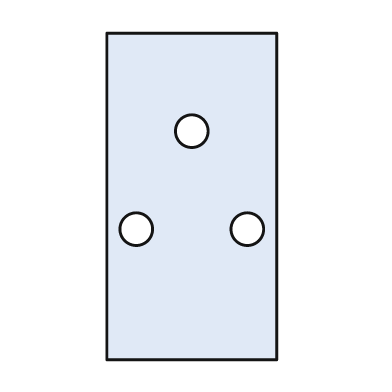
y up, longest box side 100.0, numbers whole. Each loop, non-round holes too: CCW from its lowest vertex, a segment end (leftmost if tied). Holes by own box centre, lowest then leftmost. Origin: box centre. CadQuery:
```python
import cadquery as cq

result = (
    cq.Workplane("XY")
    .moveTo(-26.0, -50.0)
    .lineTo(26.0, -50.0)
    .lineTo(26.0, 50.0)
    .lineTo(-26.0, 50.0)
    .close()
    .moveTo(-17.0, -10.0)
    .circle(5.0)
    .moveTo(17.0, -10.0)
    .circle(5.0)
    .moveTo(0.0, 20.0)
    .circle(5.0)
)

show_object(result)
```